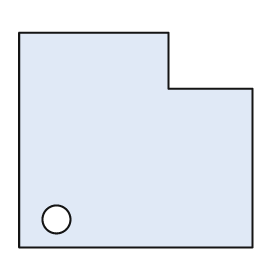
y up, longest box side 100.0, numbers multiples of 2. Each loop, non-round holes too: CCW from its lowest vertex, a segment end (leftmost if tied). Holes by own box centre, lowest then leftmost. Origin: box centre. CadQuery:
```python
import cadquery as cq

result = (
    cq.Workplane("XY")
    .moveTo(-50.0, -46.0)
    .lineTo(50.0, -46.0)
    .lineTo(50.0, 22.0)
    .lineTo(14.0, 22.0)
    .lineTo(14.0, 46.0)
    .lineTo(-50.0, 46.0)
    .close()
    .moveTo(-34.0, -34.0)
    .circle(6.0)
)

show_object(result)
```